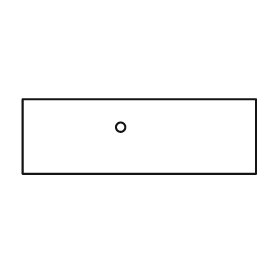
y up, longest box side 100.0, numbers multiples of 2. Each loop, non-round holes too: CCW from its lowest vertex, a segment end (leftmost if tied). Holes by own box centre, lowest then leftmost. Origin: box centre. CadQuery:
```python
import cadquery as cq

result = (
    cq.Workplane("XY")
    .moveTo(-50.0, -16.0)
    .lineTo(50.0, -16.0)
    .lineTo(50.0, 16.0)
    .lineTo(-50.0, 16.0)
    .close()
    .moveTo(-8.0, 4.0)
    .circle(2.0)
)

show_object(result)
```